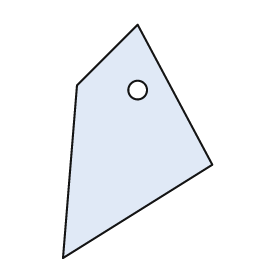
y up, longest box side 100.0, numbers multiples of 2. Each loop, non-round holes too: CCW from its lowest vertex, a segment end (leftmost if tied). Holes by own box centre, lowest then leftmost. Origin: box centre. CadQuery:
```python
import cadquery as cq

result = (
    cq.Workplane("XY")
    .moveTo(-32.0, -50.0)
    .lineTo(32.0, -10.0)
    .lineTo(0.0, 50.0)
    .lineTo(-26.0, 24.0)
    .close()
    .moveTo(0.0, 22.0)
    .circle(4.0)
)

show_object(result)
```